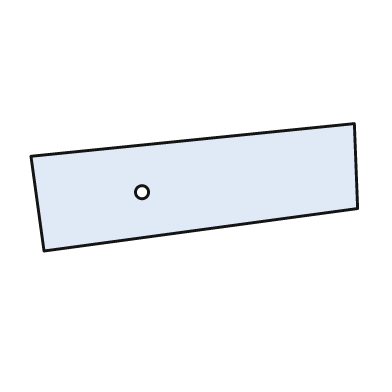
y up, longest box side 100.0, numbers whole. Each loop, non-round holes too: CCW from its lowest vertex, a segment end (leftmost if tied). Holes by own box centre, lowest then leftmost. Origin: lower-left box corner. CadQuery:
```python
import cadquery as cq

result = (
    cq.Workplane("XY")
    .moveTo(4.0, 0.0)
    .lineTo(100.0, 13.0)
    .lineTo(99.0, 39.0)
    .lineTo(0.0, 29.0)
    .close()
    .moveTo(34.0, 18.0)
    .circle(2.0)
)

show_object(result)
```